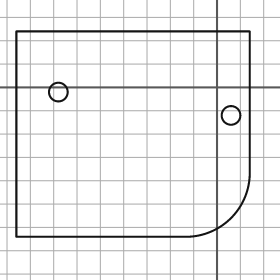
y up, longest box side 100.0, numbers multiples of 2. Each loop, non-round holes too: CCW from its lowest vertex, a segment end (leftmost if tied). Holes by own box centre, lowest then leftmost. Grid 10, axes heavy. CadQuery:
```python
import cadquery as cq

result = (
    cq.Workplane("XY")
    .moveTo(-86.0, -64.0)
    .lineTo(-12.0, -64.0)
    .threePointArc((6.0, -56.0), (14.0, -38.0))
    .lineTo(14.0, 24.0)
    .lineTo(-86.0, 24.0)
    .close()
    .moveTo(6.0, -12.0)
    .circle(4.0)
    .moveTo(-68.0, -2.0)
    .circle(4.0)
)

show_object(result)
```